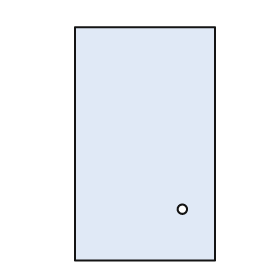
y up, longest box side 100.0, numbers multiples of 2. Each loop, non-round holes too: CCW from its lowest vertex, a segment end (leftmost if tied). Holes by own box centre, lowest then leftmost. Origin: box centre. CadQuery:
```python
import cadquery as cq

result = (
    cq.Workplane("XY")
    .moveTo(-30.0, -50.0)
    .lineTo(30.0, -50.0)
    .lineTo(30.0, 50.0)
    .lineTo(-30.0, 50.0)
    .close()
    .moveTo(16.0, -28.0)
    .circle(2.0)
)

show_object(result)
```